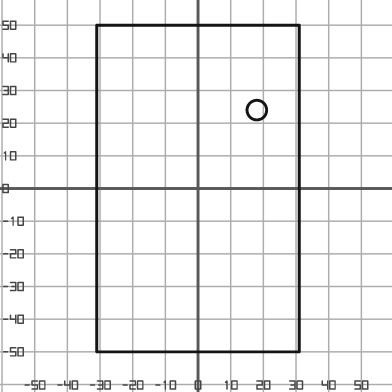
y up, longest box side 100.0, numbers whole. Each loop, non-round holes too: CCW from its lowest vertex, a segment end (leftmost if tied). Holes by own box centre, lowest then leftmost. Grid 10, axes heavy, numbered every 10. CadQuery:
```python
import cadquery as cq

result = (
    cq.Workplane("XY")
    .moveTo(-31.0, -50.0)
    .lineTo(31.0, -50.0)
    .lineTo(31.0, 50.0)
    .lineTo(-31.0, 50.0)
    .close()
    .moveTo(18.0, 24.0)
    .circle(3.0)
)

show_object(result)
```